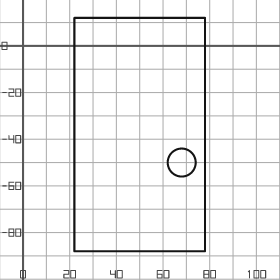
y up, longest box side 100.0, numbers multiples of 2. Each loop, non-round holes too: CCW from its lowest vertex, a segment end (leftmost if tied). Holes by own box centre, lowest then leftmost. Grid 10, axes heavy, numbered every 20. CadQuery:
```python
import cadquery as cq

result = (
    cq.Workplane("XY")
    .moveTo(22.0, -88.0)
    .lineTo(78.0, -88.0)
    .lineTo(78.0, 12.0)
    .lineTo(22.0, 12.0)
    .close()
    .moveTo(68.0, -50.0)
    .circle(6.0)
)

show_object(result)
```